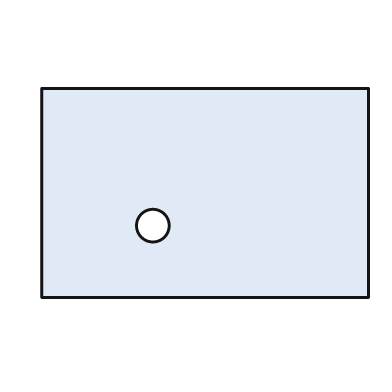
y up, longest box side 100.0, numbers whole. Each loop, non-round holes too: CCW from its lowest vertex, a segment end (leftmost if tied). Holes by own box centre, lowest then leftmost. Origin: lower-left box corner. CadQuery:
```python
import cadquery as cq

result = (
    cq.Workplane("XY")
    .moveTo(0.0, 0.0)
    .lineTo(100.0, 0.0)
    .lineTo(100.0, 64.0)
    .lineTo(0.0, 64.0)
    .close()
    .moveTo(34.0, 22.0)
    .circle(5.0)
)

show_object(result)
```